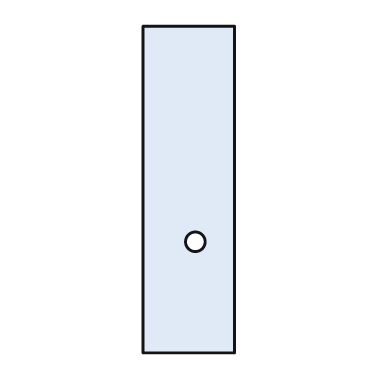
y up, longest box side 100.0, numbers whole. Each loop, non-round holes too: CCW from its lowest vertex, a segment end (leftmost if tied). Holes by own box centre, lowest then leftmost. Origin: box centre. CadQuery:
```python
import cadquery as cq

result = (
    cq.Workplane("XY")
    .moveTo(-14.0, -50.0)
    .lineTo(14.0, -50.0)
    .lineTo(14.0, 50.0)
    .lineTo(-14.0, 50.0)
    .close()
    .moveTo(2.0, -16.0)
    .circle(3.0)
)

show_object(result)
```